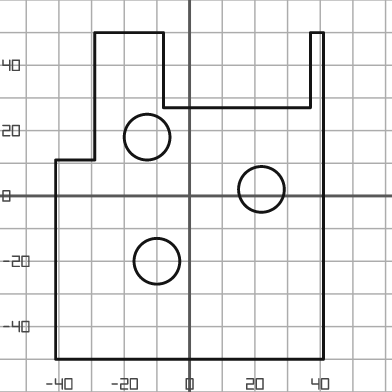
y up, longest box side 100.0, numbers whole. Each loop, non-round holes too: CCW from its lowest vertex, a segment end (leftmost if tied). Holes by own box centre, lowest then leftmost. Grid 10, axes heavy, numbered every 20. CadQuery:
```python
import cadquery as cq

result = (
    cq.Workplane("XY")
    .moveTo(-41.0, -50.0)
    .lineTo(41.0, -50.0)
    .lineTo(41.0, 50.0)
    .lineTo(37.0, 50.0)
    .lineTo(37.0, 27.0)
    .lineTo(-8.0, 27.0)
    .lineTo(-8.0, 50.0)
    .lineTo(-29.0, 50.0)
    .lineTo(-29.0, 11.0)
    .lineTo(-41.0, 11.0)
    .close()
    .moveTo(-10.0, -20.0)
    .circle(7.0)
    .moveTo(22.0, 2.0)
    .circle(7.0)
    .moveTo(-13.0, 18.0)
    .circle(7.0)
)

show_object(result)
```